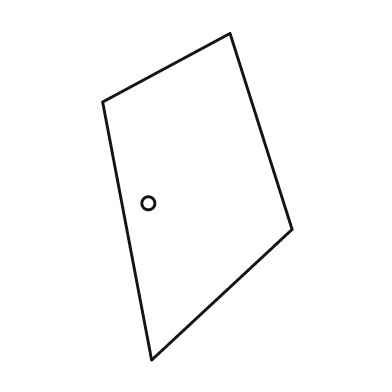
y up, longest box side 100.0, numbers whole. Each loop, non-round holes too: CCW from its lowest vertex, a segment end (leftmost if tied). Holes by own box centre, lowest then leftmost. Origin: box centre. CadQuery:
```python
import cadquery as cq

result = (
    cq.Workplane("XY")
    .moveTo(-14.0, -50.0)
    .lineTo(29.0, -10.0)
    .lineTo(10.0, 50.0)
    .lineTo(-29.0, 29.0)
    .close()
    .moveTo(-15.0, -2.0)
    .circle(2.0)
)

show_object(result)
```